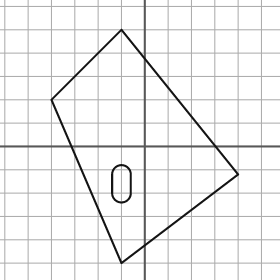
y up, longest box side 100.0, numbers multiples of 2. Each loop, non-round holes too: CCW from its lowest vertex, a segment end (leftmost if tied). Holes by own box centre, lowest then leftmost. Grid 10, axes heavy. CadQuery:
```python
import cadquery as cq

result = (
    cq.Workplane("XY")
    .moveTo(-10.0, -50.0)
    .lineTo(40.0, -12.0)
    .lineTo(-10.0, 50.0)
    .lineTo(-40.0, 20.0)
    .close()
    .moveTo(-14.0, -20.0)
    .threePointArc((-10.0, -24.0), (-6.0, -20.0))
    .lineTo(-6.0, -12.0)
    .threePointArc((-10.0, -8.0), (-14.0, -12.0))
    .close()
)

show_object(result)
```